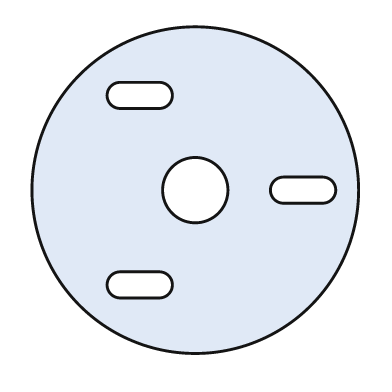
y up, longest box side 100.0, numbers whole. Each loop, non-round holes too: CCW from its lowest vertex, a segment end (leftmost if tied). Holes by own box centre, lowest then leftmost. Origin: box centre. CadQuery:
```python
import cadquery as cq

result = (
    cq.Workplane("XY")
    .moveTo(0.0, 0.0)
    .circle(50.0)
    .moveTo(-23.0, -33.0)
    .lineTo(-11.0, -33.0)
    .threePointArc((-7.0, -29.0), (-11.0, -25.0))
    .lineTo(-23.0, -25.0)
    .threePointArc((-27.0, -29.0), (-23.0, -33.0))
    .close()
    .moveTo(0.0, 0.0)
    .circle(10.0)
    .moveTo(27.0, -4.0)
    .lineTo(39.0, -4.0)
    .threePointArc((43.0, 0.0), (39.0, 4.0))
    .lineTo(27.0, 4.0)
    .threePointArc((23.0, 0.0), (27.0, -4.0))
    .close()
    .moveTo(-23.0, 25.0)
    .lineTo(-11.0, 25.0)
    .threePointArc((-7.0, 29.0), (-11.0, 33.0))
    .lineTo(-23.0, 33.0)
    .threePointArc((-27.0, 29.0), (-23.0, 25.0))
    .close()
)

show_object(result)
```